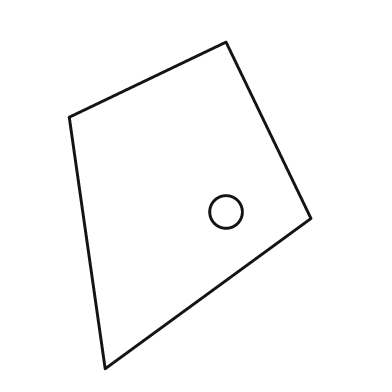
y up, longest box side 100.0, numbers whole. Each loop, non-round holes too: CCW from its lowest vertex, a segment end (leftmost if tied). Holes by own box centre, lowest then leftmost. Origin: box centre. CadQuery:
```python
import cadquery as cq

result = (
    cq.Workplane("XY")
    .moveTo(-26.0, -50.0)
    .lineTo(37.0, -4.0)
    .lineTo(11.0, 50.0)
    .lineTo(-37.0, 27.0)
    .close()
    .moveTo(11.0, -2.0)
    .circle(5.0)
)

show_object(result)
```